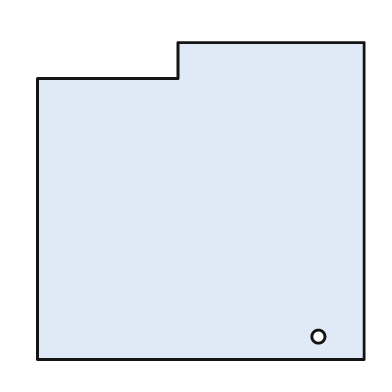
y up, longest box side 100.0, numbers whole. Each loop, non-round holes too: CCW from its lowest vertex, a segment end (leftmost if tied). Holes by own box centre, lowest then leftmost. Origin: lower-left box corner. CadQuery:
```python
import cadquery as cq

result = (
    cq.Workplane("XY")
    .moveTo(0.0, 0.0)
    .lineTo(100.0, 0.0)
    .lineTo(100.0, 97.0)
    .lineTo(43.0, 97.0)
    .lineTo(43.0, 86.0)
    .lineTo(0.0, 86.0)
    .close()
    .moveTo(86.0, 7.0)
    .circle(2.0)
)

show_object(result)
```